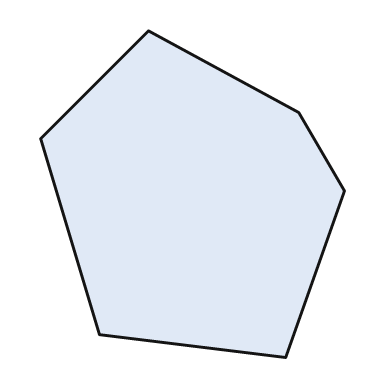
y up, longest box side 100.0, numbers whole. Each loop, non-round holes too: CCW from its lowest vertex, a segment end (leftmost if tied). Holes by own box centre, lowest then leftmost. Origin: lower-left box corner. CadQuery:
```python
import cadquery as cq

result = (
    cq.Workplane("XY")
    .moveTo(75.0, 0.0)
    .lineTo(93.0, 51.0)
    .lineTo(79.0, 75.0)
    .lineTo(33.0, 100.0)
    .lineTo(0.0, 67.0)
    .lineTo(18.0, 7.0)
    .close()
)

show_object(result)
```